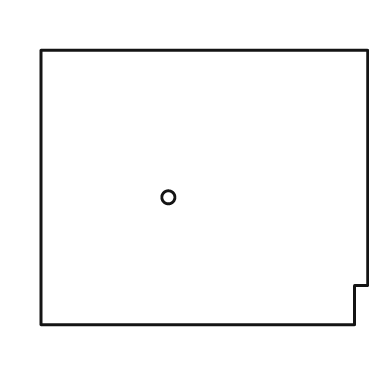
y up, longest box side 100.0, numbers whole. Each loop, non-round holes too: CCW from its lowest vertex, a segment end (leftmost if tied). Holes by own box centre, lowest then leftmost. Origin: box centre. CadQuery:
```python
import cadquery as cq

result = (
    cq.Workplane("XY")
    .moveTo(-50.0, -42.0)
    .lineTo(46.0, -42.0)
    .lineTo(46.0, -30.0)
    .lineTo(50.0, -30.0)
    .lineTo(50.0, 42.0)
    .lineTo(-50.0, 42.0)
    .close()
    .moveTo(-11.0, -3.0)
    .circle(2.0)
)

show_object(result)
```